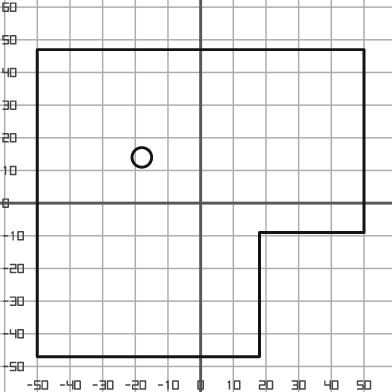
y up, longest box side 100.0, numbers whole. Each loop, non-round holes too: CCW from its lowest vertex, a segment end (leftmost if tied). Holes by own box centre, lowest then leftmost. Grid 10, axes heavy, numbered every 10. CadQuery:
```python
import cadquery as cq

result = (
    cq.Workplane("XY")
    .moveTo(-50.0, -47.0)
    .lineTo(18.0, -47.0)
    .lineTo(18.0, -9.0)
    .lineTo(50.0, -9.0)
    .lineTo(50.0, 47.0)
    .lineTo(-50.0, 47.0)
    .close()
    .moveTo(-18.0, 14.0)
    .circle(3.0)
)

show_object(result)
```